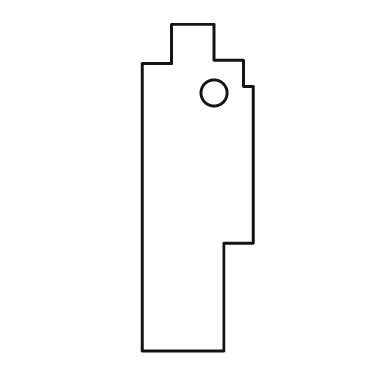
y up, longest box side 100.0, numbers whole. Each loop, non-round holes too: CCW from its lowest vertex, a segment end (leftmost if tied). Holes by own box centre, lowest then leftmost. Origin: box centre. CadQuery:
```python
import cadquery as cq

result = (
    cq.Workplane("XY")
    .moveTo(-17.0, -50.0)
    .lineTo(8.0, -50.0)
    .lineTo(8.0, -17.0)
    .lineTo(17.0, -17.0)
    .lineTo(17.0, 31.0)
    .lineTo(14.0, 31.0)
    .lineTo(14.0, 39.0)
    .lineTo(5.0, 39.0)
    .lineTo(5.0, 50.0)
    .lineTo(-8.0, 50.0)
    .lineTo(-8.0, 38.0)
    .lineTo(-17.0, 38.0)
    .close()
    .moveTo(5.0, 29.0)
    .circle(4.0)
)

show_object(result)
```